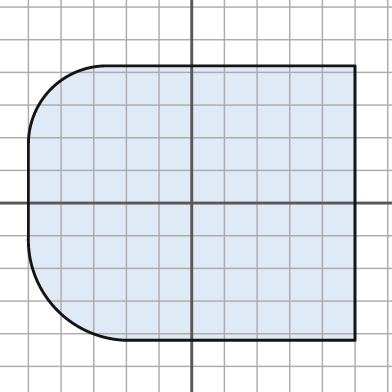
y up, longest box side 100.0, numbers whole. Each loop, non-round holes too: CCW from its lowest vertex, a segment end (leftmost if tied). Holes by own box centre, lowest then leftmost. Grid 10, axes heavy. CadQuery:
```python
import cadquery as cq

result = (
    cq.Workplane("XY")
    .moveTo(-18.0, -42.0)
    .lineTo(50.0, -42.0)
    .lineTo(50.0, 42.0)
    .lineTo(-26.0, 42.0)
    .threePointArc((-43.0, 35.0), (-50.0, 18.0))
    .lineTo(-50.0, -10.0)
    .threePointArc((-41.0, -33.0), (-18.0, -42.0))
    .close()
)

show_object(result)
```